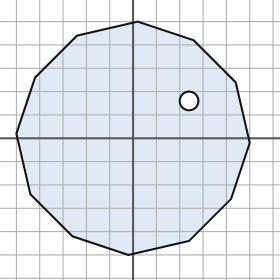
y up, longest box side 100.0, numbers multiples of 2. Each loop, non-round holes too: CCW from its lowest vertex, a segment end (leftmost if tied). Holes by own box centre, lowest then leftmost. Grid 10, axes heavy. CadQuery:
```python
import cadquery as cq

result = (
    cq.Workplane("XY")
    .moveTo(-2.0, -50.0)
    .lineTo(24.0, -44.0)
    .lineTo(42.0, -26.0)
    .lineTo(50.0, -2.0)
    .lineTo(44.0, 24.0)
    .lineTo(26.0, 42.0)
    .lineTo(2.0, 50.0)
    .lineTo(-24.0, 44.0)
    .lineTo(-42.0, 26.0)
    .lineTo(-50.0, 2.0)
    .lineTo(-44.0, -24.0)
    .lineTo(-26.0, -42.0)
    .close()
    .moveTo(24.0, 16.0)
    .circle(4.0)
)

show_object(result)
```